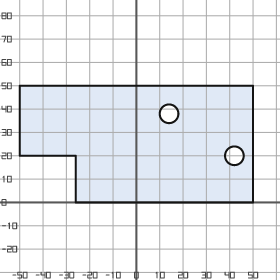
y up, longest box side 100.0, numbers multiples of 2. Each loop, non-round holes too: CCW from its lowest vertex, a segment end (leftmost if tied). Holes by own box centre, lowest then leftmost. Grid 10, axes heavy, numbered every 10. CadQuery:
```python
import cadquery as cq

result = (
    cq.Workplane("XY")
    .moveTo(-26.0, 0.0)
    .lineTo(50.0, 0.0)
    .lineTo(50.0, 50.0)
    .lineTo(-50.0, 50.0)
    .lineTo(-50.0, 20.0)
    .lineTo(-26.0, 20.0)
    .close()
    .moveTo(42.0, 20.0)
    .circle(4.0)
    .moveTo(14.0, 38.0)
    .circle(4.0)
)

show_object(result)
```